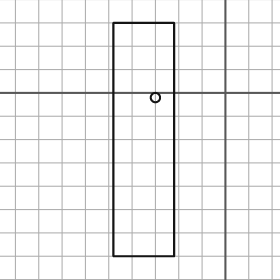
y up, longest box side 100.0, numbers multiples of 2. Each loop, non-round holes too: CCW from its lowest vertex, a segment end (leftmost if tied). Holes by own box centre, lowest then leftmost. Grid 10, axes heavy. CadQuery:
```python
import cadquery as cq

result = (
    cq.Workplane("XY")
    .moveTo(-48.0, -70.0)
    .lineTo(-22.0, -70.0)
    .lineTo(-22.0, 30.0)
    .lineTo(-48.0, 30.0)
    .close()
    .moveTo(-30.0, -2.0)
    .circle(2.0)
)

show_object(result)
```